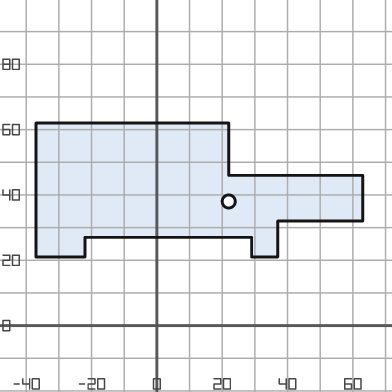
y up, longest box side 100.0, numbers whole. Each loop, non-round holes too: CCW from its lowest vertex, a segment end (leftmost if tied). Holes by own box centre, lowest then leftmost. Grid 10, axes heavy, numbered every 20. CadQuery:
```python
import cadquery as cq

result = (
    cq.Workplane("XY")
    .moveTo(-37.0, 21.0)
    .lineTo(-22.0, 21.0)
    .lineTo(-22.0, 27.0)
    .lineTo(29.0, 27.0)
    .lineTo(29.0, 21.0)
    .lineTo(37.0, 21.0)
    .lineTo(37.0, 32.0)
    .lineTo(63.0, 32.0)
    .lineTo(63.0, 46.0)
    .lineTo(22.0, 46.0)
    .lineTo(22.0, 62.0)
    .lineTo(-37.0, 62.0)
    .close()
    .moveTo(22.0, 38.0)
    .circle(2.0)
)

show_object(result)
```